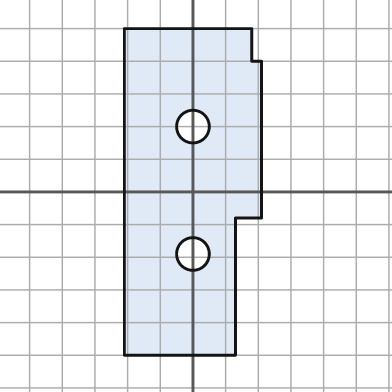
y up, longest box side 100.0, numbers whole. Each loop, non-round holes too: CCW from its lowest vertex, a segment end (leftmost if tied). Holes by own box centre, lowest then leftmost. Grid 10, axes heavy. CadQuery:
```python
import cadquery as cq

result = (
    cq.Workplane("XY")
    .moveTo(-21.0, -50.0)
    .lineTo(13.0, -50.0)
    .lineTo(13.0, -8.0)
    .lineTo(21.0, -8.0)
    .lineTo(21.0, 40.0)
    .lineTo(18.0, 40.0)
    .lineTo(18.0, 50.0)
    .lineTo(-21.0, 50.0)
    .close()
    .moveTo(0.0, -19.0)
    .circle(5.0)
    .moveTo(0.0, 20.0)
    .circle(5.0)
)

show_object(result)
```